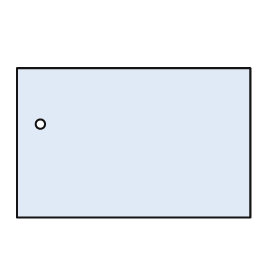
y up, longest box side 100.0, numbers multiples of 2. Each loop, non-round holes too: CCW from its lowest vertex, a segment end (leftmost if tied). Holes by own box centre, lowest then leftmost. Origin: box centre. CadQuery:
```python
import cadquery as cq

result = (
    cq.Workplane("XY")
    .moveTo(-50.0, -32.0)
    .lineTo(50.0, -32.0)
    .lineTo(50.0, 32.0)
    .lineTo(-50.0, 32.0)
    .close()
    .moveTo(-40.0, 8.0)
    .circle(2.0)
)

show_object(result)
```